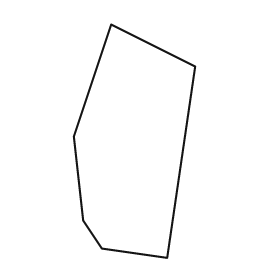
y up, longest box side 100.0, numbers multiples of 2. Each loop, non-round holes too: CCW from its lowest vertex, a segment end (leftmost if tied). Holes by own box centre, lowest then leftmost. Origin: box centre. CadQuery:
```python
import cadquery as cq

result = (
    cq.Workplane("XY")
    .moveTo(14.0, -50.0)
    .lineTo(26.0, 32.0)
    .lineTo(-10.0, 50.0)
    .lineTo(-26.0, 2.0)
    .lineTo(-22.0, -34.0)
    .lineTo(-14.0, -46.0)
    .close()
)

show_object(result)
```